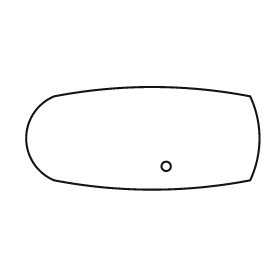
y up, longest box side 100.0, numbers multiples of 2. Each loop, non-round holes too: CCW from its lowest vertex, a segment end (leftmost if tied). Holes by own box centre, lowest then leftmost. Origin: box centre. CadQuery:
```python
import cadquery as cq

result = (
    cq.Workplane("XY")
    .moveTo(-38.0, -18.0)
    .threePointArc((4.0, -22.0), (46.0, -18.0))
    .threePointArc((50.0, 0.0), (46.0, 18.0))
    .threePointArc((4.0, 22.0), (-38.0, 18.0))
    .threePointArc((-50.0, 0.0), (-38.0, -18.0))
    .close()
    .moveTo(10.0, -12.0)
    .circle(2.0)
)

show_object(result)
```